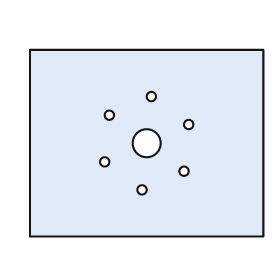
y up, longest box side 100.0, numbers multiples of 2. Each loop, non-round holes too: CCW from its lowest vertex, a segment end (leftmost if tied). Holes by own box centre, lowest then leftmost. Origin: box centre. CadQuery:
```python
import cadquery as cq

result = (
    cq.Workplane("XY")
    .moveTo(-50.0, -40.0)
    .lineTo(50.0, -40.0)
    .lineTo(50.0, 40.0)
    .lineTo(-50.0, 40.0)
    .close()
    .moveTo(-2.0, -20.0)
    .circle(2.0)
    .moveTo(16.0, -12.0)
    .circle(2.0)
    .moveTo(-18.0, -8.0)
    .circle(2.0)
    .moveTo(0.0, 0.0)
    .circle(6.0)
    .moveTo(18.0, 8.0)
    .circle(2.0)
    .moveTo(-16.0, 12.0)
    .circle(2.0)
    .moveTo(2.0, 20.0)
    .circle(2.0)
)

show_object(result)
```